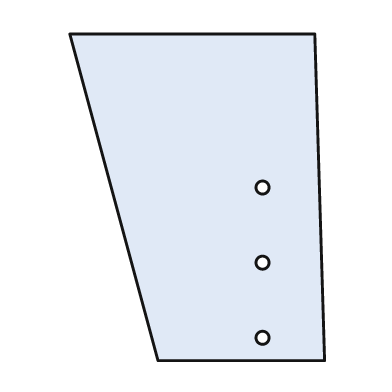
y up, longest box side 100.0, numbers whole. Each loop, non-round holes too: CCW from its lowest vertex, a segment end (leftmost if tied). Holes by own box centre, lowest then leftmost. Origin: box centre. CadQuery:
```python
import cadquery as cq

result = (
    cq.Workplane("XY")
    .moveTo(-12.0, -50.0)
    .lineTo(39.0, -50.0)
    .lineTo(36.0, 50.0)
    .lineTo(-39.0, 50.0)
    .close()
    .moveTo(20.0, -43.0)
    .circle(2.0)
    .moveTo(20.0, -20.0)
    .circle(2.0)
    .moveTo(20.0, 3.0)
    .circle(2.0)
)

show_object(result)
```